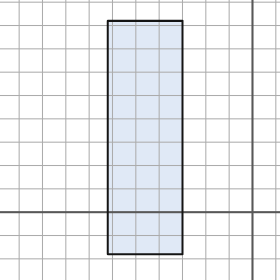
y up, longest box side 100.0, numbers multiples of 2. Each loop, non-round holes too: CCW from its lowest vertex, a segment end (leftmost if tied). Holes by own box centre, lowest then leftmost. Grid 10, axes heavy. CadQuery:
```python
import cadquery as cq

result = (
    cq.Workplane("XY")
    .moveTo(-62.0, -18.0)
    .lineTo(-30.0, -18.0)
    .lineTo(-30.0, 82.0)
    .lineTo(-62.0, 82.0)
    .close()
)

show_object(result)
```